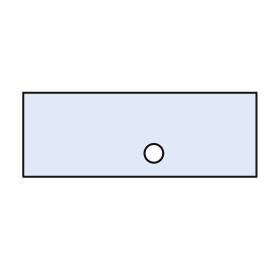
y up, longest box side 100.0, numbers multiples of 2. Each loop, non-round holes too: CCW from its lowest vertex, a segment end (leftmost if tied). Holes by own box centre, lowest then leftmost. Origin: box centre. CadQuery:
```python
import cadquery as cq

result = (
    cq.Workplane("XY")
    .moveTo(-50.0, -18.0)
    .lineTo(50.0, -18.0)
    .lineTo(50.0, 18.0)
    .lineTo(-50.0, 18.0)
    .close()
    .moveTo(6.0, -8.0)
    .circle(4.0)
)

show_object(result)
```